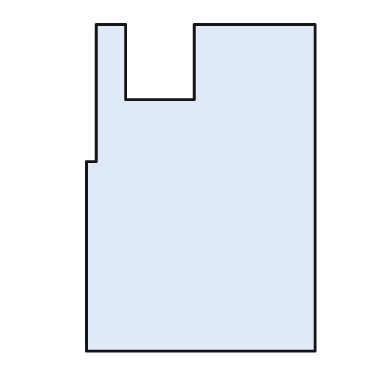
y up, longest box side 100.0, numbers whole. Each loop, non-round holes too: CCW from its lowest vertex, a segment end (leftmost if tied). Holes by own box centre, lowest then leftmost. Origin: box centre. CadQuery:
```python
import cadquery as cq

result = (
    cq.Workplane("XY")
    .moveTo(-35.0, -50.0)
    .lineTo(35.0, -50.0)
    .lineTo(35.0, 50.0)
    .lineTo(-2.0, 50.0)
    .lineTo(-2.0, 27.0)
    .lineTo(-23.0, 27.0)
    .lineTo(-23.0, 50.0)
    .lineTo(-32.0, 50.0)
    .lineTo(-32.0, 8.0)
    .lineTo(-35.0, 8.0)
    .close()
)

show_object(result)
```